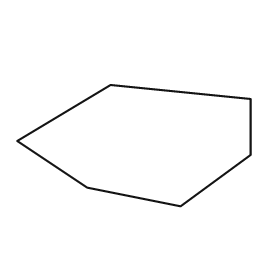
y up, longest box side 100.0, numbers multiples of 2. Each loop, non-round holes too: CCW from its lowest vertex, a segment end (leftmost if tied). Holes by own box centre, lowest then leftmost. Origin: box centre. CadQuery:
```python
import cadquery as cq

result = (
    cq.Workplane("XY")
    .moveTo(20.0, -26.0)
    .lineTo(50.0, -4.0)
    .lineTo(50.0, 20.0)
    .lineTo(-10.0, 26.0)
    .lineTo(-50.0, 2.0)
    .lineTo(-20.0, -18.0)
    .close()
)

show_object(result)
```